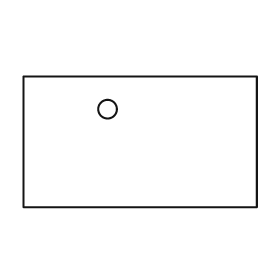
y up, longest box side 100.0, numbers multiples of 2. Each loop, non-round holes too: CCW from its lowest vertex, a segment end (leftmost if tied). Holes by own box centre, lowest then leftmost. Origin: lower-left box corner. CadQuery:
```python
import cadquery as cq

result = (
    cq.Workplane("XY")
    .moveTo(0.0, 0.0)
    .lineTo(100.0, 0.0)
    .lineTo(100.0, 56.0)
    .lineTo(0.0, 56.0)
    .close()
    .moveTo(36.0, 42.0)
    .circle(4.0)
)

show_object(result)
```